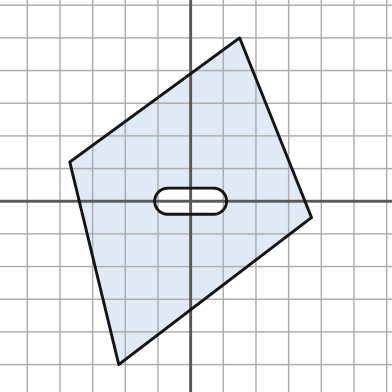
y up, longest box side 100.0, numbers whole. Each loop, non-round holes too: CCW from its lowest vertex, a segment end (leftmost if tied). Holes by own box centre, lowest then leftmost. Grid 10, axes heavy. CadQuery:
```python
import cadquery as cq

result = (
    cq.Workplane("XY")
    .moveTo(-22.0, -50.0)
    .lineTo(37.0, -5.0)
    .lineTo(15.0, 50.0)
    .lineTo(-37.0, 12.0)
    .close()
    .moveTo(-7.0, -4.0)
    .lineTo(7.0, -4.0)
    .threePointArc((11.0, 0.0), (7.0, 4.0))
    .lineTo(-7.0, 4.0)
    .threePointArc((-11.0, 0.0), (-7.0, -4.0))
    .close()
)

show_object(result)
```